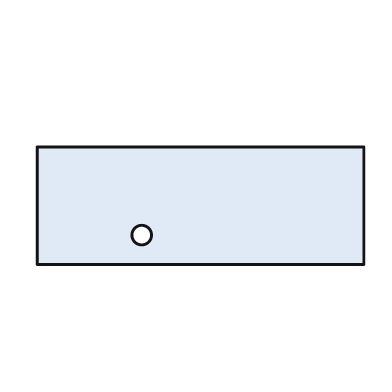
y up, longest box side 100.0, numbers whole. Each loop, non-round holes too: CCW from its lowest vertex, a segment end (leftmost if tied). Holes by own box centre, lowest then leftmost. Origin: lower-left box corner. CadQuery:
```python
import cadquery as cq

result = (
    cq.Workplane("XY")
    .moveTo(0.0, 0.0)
    .lineTo(100.0, 0.0)
    .lineTo(100.0, 36.0)
    .lineTo(0.0, 36.0)
    .close()
    .moveTo(32.0, 9.0)
    .circle(3.0)
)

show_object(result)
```